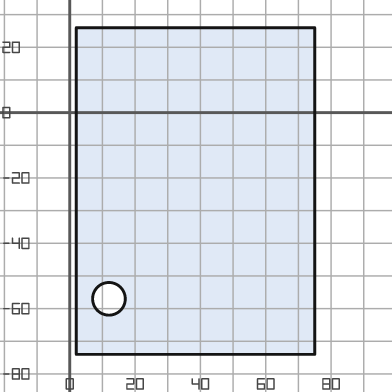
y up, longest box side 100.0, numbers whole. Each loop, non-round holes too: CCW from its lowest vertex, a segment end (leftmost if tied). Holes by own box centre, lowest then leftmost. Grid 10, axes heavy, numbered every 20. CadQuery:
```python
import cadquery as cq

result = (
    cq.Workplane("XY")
    .moveTo(2.0, -74.0)
    .lineTo(75.0, -74.0)
    .lineTo(75.0, 26.0)
    .lineTo(2.0, 26.0)
    .close()
    .moveTo(12.0, -57.0)
    .circle(5.0)
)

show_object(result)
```